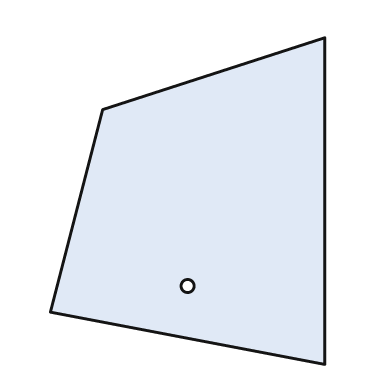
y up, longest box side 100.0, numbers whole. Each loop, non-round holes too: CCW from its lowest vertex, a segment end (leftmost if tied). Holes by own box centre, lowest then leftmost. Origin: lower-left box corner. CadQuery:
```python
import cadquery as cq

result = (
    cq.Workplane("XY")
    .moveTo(84.0, 0.0)
    .lineTo(84.0, 100.0)
    .lineTo(16.0, 78.0)
    .lineTo(0.0, 16.0)
    .close()
    .moveTo(42.0, 24.0)
    .circle(2.0)
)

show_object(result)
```